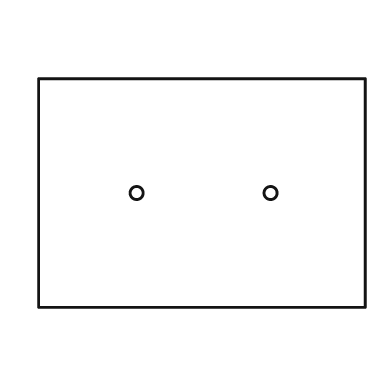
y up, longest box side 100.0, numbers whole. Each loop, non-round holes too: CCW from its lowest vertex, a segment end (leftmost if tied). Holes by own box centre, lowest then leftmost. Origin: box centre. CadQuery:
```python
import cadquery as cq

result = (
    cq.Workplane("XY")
    .moveTo(-50.0, -35.0)
    .lineTo(50.0, -35.0)
    .lineTo(50.0, 35.0)
    .lineTo(-50.0, 35.0)
    .close()
    .moveTo(-20.0, 0.0)
    .circle(2.0)
    .moveTo(21.0, 0.0)
    .circle(2.0)
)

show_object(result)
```